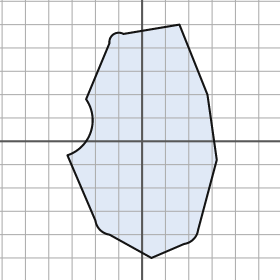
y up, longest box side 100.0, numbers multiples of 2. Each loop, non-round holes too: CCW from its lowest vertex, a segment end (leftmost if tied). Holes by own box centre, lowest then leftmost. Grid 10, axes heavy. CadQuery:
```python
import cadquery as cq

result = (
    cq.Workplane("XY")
    .moveTo(4.0, -50.0)
    .lineTo(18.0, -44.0)
    .threePointArc((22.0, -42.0), (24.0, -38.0))
    .lineTo(32.0, -8.0)
    .lineTo(28.0, 20.0)
    .lineTo(16.0, 50.0)
    .lineTo(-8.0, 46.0)
    .threePointArc((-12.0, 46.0), (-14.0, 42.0))
    .lineTo(-24.0, 18.0)
    .threePointArc((-22.0, 4.0), (-32.0, -6.0))
    .lineTo(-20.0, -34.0)
    .threePointArc((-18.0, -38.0), (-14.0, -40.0))
    .close()
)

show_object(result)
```